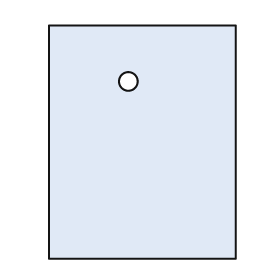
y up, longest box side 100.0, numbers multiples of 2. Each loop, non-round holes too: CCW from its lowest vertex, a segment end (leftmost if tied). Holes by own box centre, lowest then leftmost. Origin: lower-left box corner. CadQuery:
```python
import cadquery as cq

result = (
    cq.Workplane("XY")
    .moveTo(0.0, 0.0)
    .lineTo(80.0, 0.0)
    .lineTo(80.0, 100.0)
    .lineTo(0.0, 100.0)
    .close()
    .moveTo(34.0, 76.0)
    .circle(4.0)
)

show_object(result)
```